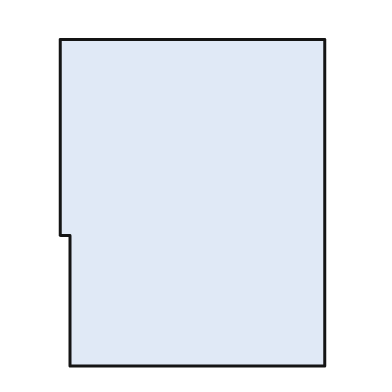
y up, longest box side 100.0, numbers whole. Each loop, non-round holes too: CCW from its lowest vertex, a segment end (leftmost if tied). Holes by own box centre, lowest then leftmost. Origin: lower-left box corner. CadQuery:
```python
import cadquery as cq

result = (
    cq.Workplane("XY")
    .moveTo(3.0, 0.0)
    .lineTo(81.0, 0.0)
    .lineTo(81.0, 100.0)
    .lineTo(0.0, 100.0)
    .lineTo(0.0, 40.0)
    .lineTo(3.0, 40.0)
    .close()
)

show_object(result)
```